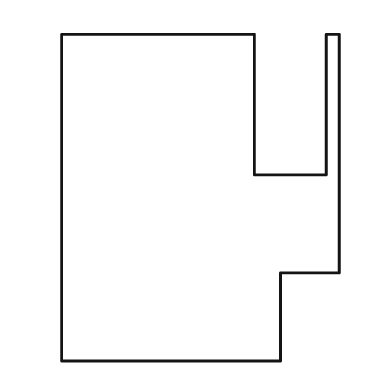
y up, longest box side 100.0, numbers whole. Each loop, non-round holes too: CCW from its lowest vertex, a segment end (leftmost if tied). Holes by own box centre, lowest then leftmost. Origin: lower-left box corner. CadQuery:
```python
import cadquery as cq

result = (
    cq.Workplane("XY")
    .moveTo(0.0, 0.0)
    .lineTo(67.0, 0.0)
    .lineTo(67.0, 27.0)
    .lineTo(85.0, 27.0)
    .lineTo(85.0, 100.0)
    .lineTo(81.0, 100.0)
    .lineTo(81.0, 57.0)
    .lineTo(59.0, 57.0)
    .lineTo(59.0, 100.0)
    .lineTo(0.0, 100.0)
    .close()
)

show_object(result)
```